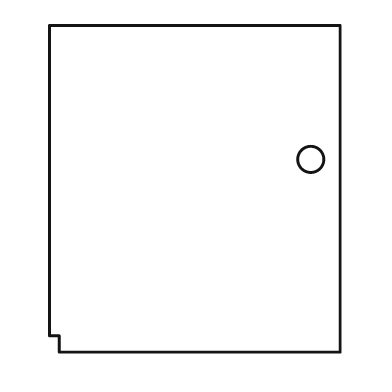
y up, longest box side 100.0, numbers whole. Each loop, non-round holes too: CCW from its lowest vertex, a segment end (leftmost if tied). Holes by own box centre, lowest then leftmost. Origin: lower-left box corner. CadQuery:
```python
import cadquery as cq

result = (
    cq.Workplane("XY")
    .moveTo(3.0, 0.0)
    .lineTo(89.0, 0.0)
    .lineTo(89.0, 100.0)
    .lineTo(0.0, 100.0)
    .lineTo(0.0, 5.0)
    .lineTo(3.0, 5.0)
    .close()
    .moveTo(80.0, 59.0)
    .circle(4.0)
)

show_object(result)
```